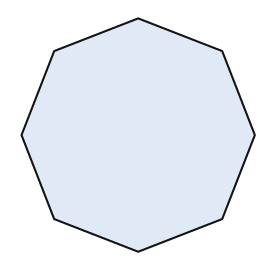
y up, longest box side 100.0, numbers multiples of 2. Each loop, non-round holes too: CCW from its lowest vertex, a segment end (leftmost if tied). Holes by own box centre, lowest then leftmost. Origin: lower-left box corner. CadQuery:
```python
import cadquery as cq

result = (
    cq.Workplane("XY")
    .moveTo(50.0, 0.0)
    .lineTo(86.0, 14.0)
    .lineTo(100.0, 50.0)
    .lineTo(86.0, 86.0)
    .lineTo(50.0, 100.0)
    .lineTo(14.0, 86.0)
    .lineTo(0.0, 50.0)
    .lineTo(14.0, 14.0)
    .close()
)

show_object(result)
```